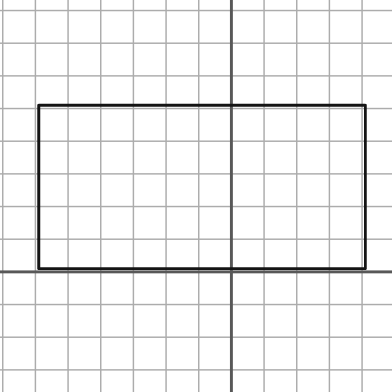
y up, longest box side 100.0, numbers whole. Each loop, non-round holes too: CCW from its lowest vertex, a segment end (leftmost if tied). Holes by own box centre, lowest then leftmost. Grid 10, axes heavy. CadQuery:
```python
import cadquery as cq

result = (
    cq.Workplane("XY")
    .moveTo(-59.0, 1.0)
    .lineTo(41.0, 1.0)
    .lineTo(41.0, 51.0)
    .lineTo(-59.0, 51.0)
    .close()
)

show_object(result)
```